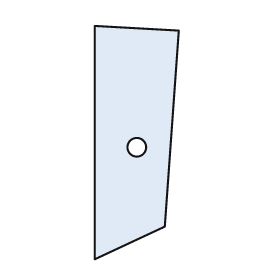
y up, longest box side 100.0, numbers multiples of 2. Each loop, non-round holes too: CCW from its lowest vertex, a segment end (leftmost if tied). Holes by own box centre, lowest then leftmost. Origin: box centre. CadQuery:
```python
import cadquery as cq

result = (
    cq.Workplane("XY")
    .moveTo(-18.0, -50.0)
    .lineTo(12.0, -36.0)
    .lineTo(18.0, 48.0)
    .lineTo(-18.0, 50.0)
    .close()
    .moveTo(0.0, -2.0)
    .circle(4.0)
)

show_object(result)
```